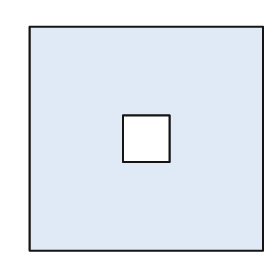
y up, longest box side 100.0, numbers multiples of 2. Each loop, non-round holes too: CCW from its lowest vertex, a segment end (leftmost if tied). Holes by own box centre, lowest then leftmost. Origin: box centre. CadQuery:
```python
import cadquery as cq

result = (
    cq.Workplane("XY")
    .moveTo(-50.0, -48.0)
    .lineTo(50.0, -48.0)
    .lineTo(50.0, 48.0)
    .lineTo(-50.0, 48.0)
    .close()
    .moveTo(-10.0, -10.0)
    .lineTo(10.0, -10.0)
    .lineTo(10.0, 10.0)
    .lineTo(-10.0, 10.0)
    .close()
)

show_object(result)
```